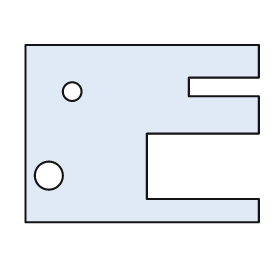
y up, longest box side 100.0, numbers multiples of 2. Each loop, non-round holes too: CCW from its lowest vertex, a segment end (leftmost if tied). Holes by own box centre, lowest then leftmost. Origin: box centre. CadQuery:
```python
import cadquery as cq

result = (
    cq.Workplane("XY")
    .moveTo(-50.0, -38.0)
    .lineTo(50.0, -38.0)
    .lineTo(50.0, -28.0)
    .lineTo(2.0, -28.0)
    .lineTo(2.0, 0.0)
    .lineTo(50.0, 0.0)
    .lineTo(50.0, 16.0)
    .lineTo(20.0, 16.0)
    .lineTo(20.0, 24.0)
    .lineTo(50.0, 24.0)
    .lineTo(50.0, 38.0)
    .lineTo(-50.0, 38.0)
    .close()
    .moveTo(-40.0, -18.0)
    .circle(6.0)
    .moveTo(-30.0, 18.0)
    .circle(4.0)
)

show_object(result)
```